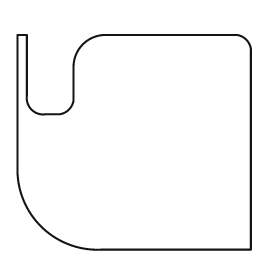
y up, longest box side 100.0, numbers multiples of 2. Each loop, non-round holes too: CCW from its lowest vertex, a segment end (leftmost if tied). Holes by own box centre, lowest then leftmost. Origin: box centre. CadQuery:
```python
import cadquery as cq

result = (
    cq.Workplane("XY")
    .moveTo(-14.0, -46.0)
    .lineTo(50.0, -46.0)
    .lineTo(50.0, 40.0)
    .threePointArc((48.0, 44.0), (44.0, 46.0))
    .lineTo(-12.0, 46.0)
    .threePointArc((-22.0, 42.0), (-26.0, 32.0))
    .lineTo(-26.0, 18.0)
    .threePointArc((-28.0, 14.0), (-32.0, 12.0))
    .lineTo(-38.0, 12.0)
    .threePointArc((-44.0, 14.0), (-46.0, 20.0))
    .lineTo(-46.0, 46.0)
    .lineTo(-50.0, 46.0)
    .lineTo(-50.0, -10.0)
    .threePointArc((-40.0, -36.0), (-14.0, -46.0))
    .close()
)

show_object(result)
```